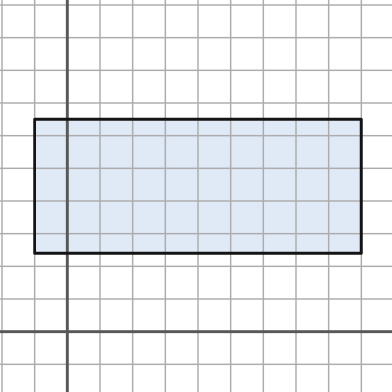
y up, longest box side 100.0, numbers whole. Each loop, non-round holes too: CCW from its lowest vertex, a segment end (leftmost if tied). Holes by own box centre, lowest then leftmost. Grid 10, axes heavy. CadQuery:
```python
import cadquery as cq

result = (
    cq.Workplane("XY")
    .moveTo(-10.0, 24.0)
    .lineTo(90.0, 24.0)
    .lineTo(90.0, 65.0)
    .lineTo(-10.0, 65.0)
    .close()
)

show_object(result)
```